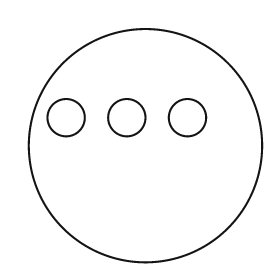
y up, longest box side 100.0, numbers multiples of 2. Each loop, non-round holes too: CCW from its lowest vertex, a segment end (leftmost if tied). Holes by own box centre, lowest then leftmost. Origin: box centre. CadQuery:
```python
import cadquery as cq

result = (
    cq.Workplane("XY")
    .moveTo(0.0, 0.0)
    .circle(50.0)
    .moveTo(-34.0, 12.0)
    .circle(8.0)
    .moveTo(-8.0, 12.0)
    .circle(8.0)
    .moveTo(18.0, 12.0)
    .circle(8.0)
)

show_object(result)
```